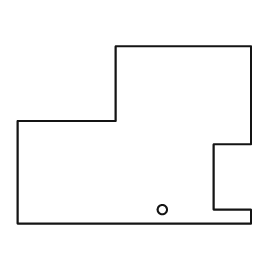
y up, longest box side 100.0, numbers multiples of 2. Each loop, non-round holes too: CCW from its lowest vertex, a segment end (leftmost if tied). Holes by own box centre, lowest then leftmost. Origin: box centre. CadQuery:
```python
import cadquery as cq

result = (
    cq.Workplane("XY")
    .moveTo(-50.0, -38.0)
    .lineTo(50.0, -38.0)
    .lineTo(50.0, -32.0)
    .lineTo(34.0, -32.0)
    .lineTo(34.0, -4.0)
    .lineTo(50.0, -4.0)
    .lineTo(50.0, 38.0)
    .lineTo(-8.0, 38.0)
    .lineTo(-8.0, 6.0)
    .lineTo(-50.0, 6.0)
    .close()
    .moveTo(12.0, -32.0)
    .circle(2.0)
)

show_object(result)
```